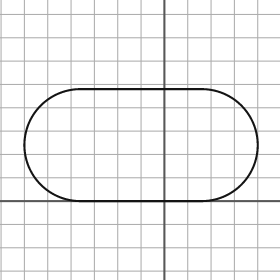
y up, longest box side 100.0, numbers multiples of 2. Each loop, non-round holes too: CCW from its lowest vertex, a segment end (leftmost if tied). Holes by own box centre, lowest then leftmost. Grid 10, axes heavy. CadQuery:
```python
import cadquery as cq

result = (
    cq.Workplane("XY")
    .moveTo(-36.0, 0.0)
    .lineTo(16.0, 0.0)
    .threePointArc((40.0, 24.0), (16.0, 48.0))
    .lineTo(-36.0, 48.0)
    .threePointArc((-60.0, 24.0), (-36.0, 0.0))
    .close()
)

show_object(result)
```